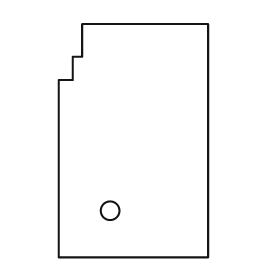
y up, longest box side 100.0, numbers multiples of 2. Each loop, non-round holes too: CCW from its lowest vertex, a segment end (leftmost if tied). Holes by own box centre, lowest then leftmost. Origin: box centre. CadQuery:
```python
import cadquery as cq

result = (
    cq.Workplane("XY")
    .moveTo(-32.0, -50.0)
    .lineTo(32.0, -50.0)
    .lineTo(32.0, 50.0)
    .lineTo(-22.0, 50.0)
    .lineTo(-22.0, 36.0)
    .lineTo(-26.0, 36.0)
    .lineTo(-26.0, 26.0)
    .lineTo(-32.0, 26.0)
    .close()
    .moveTo(-10.0, -30.0)
    .circle(4.0)
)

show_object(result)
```